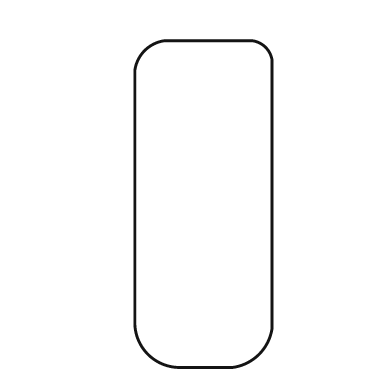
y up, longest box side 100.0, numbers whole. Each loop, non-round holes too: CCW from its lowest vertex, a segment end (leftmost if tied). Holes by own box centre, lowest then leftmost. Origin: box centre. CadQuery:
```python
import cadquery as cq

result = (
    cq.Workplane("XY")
    .moveTo(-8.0, -50.0)
    .lineTo(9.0, -50.0)
    .threePointArc((17.0, -46.0), (21.0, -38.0))
    .lineTo(21.0, 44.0)
    .threePointArc((19.0, 48.0), (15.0, 50.0))
    .lineTo(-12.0, 50.0)
    .threePointArc((-18.0, 47.0), (-21.0, 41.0))
    .lineTo(-21.0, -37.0)
    .threePointArc((-17.0, -46.0), (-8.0, -50.0))
    .close()
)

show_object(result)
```